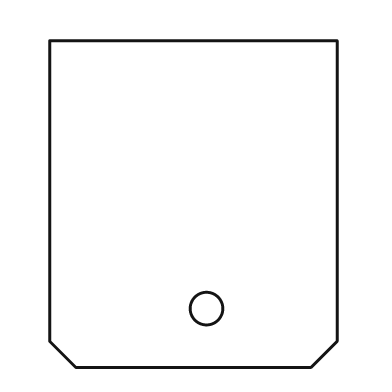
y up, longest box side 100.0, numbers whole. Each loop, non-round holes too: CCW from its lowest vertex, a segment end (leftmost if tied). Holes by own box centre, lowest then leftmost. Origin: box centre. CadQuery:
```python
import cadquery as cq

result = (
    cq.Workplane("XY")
    .moveTo(-36.0, -50.0)
    .lineTo(36.0, -50.0)
    .lineTo(44.0, -42.0)
    .lineTo(44.0, 50.0)
    .lineTo(-44.0, 50.0)
    .lineTo(-44.0, -42.0)
    .close()
    .moveTo(4.0, -32.0)
    .circle(5.0)
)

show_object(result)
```